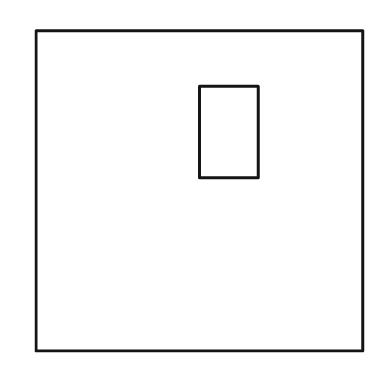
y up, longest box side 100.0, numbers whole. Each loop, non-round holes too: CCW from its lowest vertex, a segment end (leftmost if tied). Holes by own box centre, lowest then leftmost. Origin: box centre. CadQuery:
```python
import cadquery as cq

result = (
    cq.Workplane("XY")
    .moveTo(-50.0, -49.0)
    .lineTo(50.0, -49.0)
    .lineTo(50.0, 49.0)
    .lineTo(-50.0, 49.0)
    .close()
    .moveTo(0.0, 4.0)
    .lineTo(18.0, 4.0)
    .lineTo(18.0, 32.0)
    .lineTo(0.0, 32.0)
    .close()
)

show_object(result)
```